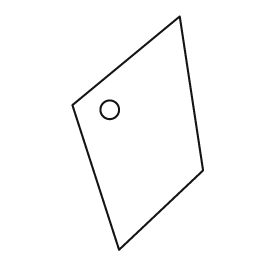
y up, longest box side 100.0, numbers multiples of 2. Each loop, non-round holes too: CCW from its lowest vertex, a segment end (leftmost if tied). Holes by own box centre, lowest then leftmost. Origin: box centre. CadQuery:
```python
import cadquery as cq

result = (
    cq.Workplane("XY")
    .moveTo(-8.0, -50.0)
    .lineTo(28.0, -16.0)
    .lineTo(18.0, 50.0)
    .lineTo(-28.0, 12.0)
    .close()
    .moveTo(-12.0, 10.0)
    .circle(4.0)
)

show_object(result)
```